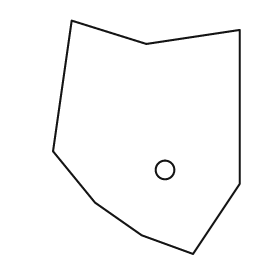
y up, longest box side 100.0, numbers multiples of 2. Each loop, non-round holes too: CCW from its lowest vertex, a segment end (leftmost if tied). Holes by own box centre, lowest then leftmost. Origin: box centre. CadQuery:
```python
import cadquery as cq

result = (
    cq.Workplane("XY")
    .moveTo(20.0, -50.0)
    .lineTo(40.0, -20.0)
    .lineTo(40.0, 46.0)
    .lineTo(0.0, 40.0)
    .lineTo(-32.0, 50.0)
    .lineTo(-40.0, -6.0)
    .lineTo(-22.0, -28.0)
    .lineTo(-2.0, -42.0)
    .close()
    .moveTo(8.0, -14.0)
    .circle(4.0)
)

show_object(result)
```